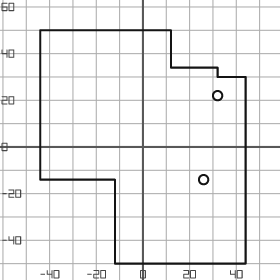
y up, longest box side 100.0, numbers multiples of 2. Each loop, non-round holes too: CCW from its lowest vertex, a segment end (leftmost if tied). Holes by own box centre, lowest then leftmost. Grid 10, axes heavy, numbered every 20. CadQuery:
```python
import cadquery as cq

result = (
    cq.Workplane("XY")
    .moveTo(-12.0, -50.0)
    .lineTo(44.0, -50.0)
    .lineTo(44.0, 30.0)
    .lineTo(32.0, 30.0)
    .lineTo(32.0, 34.0)
    .lineTo(12.0, 34.0)
    .lineTo(12.0, 50.0)
    .lineTo(-44.0, 50.0)
    .lineTo(-44.0, -14.0)
    .lineTo(-12.0, -14.0)
    .close()
    .moveTo(26.0, -14.0)
    .circle(2.0)
    .moveTo(32.0, 22.0)
    .circle(2.0)
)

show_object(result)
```